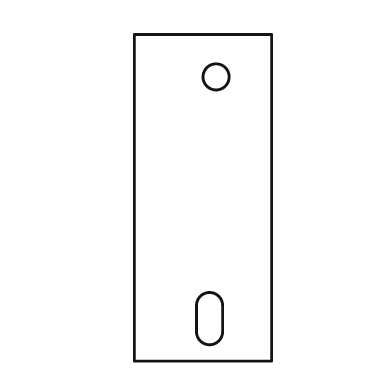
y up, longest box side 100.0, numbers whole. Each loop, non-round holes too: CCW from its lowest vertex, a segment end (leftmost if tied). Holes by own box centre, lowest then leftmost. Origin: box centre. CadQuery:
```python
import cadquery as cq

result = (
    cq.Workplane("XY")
    .moveTo(-21.0, -50.0)
    .lineTo(21.0, -50.0)
    .lineTo(21.0, 50.0)
    .lineTo(-21.0, 50.0)
    .close()
    .moveTo(-2.0, -41.0)
    .threePointArc((2.0, -45.0), (6.0, -41.0))
    .lineTo(6.0, -33.0)
    .threePointArc((2.0, -29.0), (-2.0, -33.0))
    .close()
    .moveTo(4.0, 37.0)
    .circle(4.0)
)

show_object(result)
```